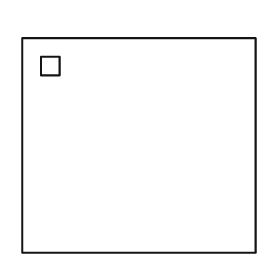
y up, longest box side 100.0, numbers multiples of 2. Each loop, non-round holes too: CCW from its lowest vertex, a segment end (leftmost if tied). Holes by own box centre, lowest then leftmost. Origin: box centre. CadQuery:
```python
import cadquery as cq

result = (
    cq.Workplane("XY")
    .moveTo(-50.0, -46.0)
    .lineTo(50.0, -46.0)
    .lineTo(50.0, 46.0)
    .lineTo(-50.0, 46.0)
    .close()
    .moveTo(-42.0, 30.0)
    .lineTo(-34.0, 30.0)
    .lineTo(-34.0, 38.0)
    .lineTo(-42.0, 38.0)
    .close()
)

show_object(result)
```